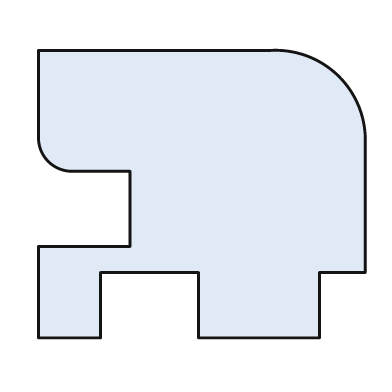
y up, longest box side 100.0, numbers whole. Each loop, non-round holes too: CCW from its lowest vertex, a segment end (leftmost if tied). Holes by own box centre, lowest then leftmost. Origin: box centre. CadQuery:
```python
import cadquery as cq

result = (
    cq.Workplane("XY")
    .moveTo(-50.0, -44.0)
    .lineTo(-31.0, -44.0)
    .lineTo(-31.0, -24.0)
    .lineTo(-1.0, -24.0)
    .lineTo(-1.0, -44.0)
    .lineTo(36.0, -44.0)
    .lineTo(36.0, -24.0)
    .lineTo(50.0, -24.0)
    .lineTo(50.0, 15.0)
    .threePointArc((42.0, 36.0), (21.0, 44.0))
    .lineTo(-50.0, 44.0)
    .lineTo(-50.0, 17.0)
    .threePointArc((-47.0, 10.0), (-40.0, 7.0))
    .lineTo(-22.0, 7.0)
    .lineTo(-22.0, -16.0)
    .lineTo(-50.0, -16.0)
    .close()
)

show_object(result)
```